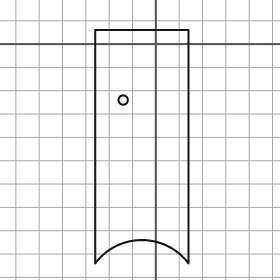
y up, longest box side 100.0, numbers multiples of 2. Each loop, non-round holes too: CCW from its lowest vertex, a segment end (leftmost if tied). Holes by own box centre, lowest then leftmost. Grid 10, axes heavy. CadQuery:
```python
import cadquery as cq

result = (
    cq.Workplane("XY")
    .moveTo(-26.0, -94.0)
    .threePointArc((-6.0, -84.0), (14.0, -94.0))
    .lineTo(14.0, 6.0)
    .lineTo(-26.0, 6.0)
    .close()
    .moveTo(-14.0, -24.0)
    .circle(2.0)
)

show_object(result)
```